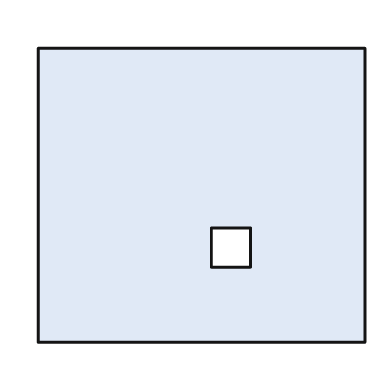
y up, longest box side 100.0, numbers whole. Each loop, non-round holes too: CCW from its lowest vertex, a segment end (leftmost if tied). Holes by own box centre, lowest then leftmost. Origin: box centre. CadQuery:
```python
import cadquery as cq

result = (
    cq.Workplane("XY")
    .moveTo(-50.0, -45.0)
    .lineTo(50.0, -45.0)
    .lineTo(50.0, 45.0)
    .lineTo(-50.0, 45.0)
    .close()
    .moveTo(3.0, -22.0)
    .lineTo(15.0, -22.0)
    .lineTo(15.0, -10.0)
    .lineTo(3.0, -10.0)
    .close()
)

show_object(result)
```